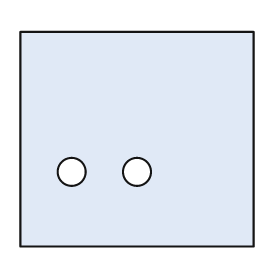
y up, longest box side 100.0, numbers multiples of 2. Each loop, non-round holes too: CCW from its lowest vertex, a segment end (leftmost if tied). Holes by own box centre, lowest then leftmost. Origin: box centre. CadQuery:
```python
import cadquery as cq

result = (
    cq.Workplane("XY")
    .moveTo(-50.0, -46.0)
    .lineTo(50.0, -46.0)
    .lineTo(50.0, 46.0)
    .lineTo(-50.0, 46.0)
    .close()
    .moveTo(-28.0, -14.0)
    .circle(6.0)
    .moveTo(0.0, -14.0)
    .circle(6.0)
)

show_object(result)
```